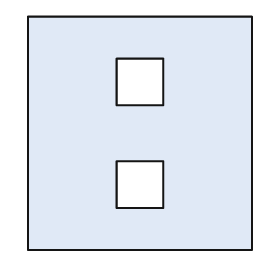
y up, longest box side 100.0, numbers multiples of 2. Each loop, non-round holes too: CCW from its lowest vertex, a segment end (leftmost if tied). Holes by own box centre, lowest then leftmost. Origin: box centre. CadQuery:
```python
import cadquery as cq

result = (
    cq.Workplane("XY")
    .moveTo(-48.0, -50.0)
    .lineTo(48.0, -50.0)
    .lineTo(48.0, 50.0)
    .lineTo(-48.0, 50.0)
    .close()
    .moveTo(-10.0, -32.0)
    .lineTo(10.0, -32.0)
    .lineTo(10.0, -12.0)
    .lineTo(-10.0, -12.0)
    .close()
    .moveTo(-10.0, 12.0)
    .lineTo(10.0, 12.0)
    .lineTo(10.0, 32.0)
    .lineTo(-10.0, 32.0)
    .close()
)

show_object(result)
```